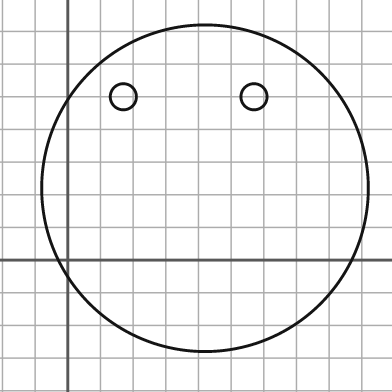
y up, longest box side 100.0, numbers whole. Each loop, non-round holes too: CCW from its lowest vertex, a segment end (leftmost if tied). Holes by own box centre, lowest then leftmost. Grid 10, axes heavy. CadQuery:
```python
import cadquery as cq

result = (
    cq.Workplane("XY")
    .moveTo(42.0, 22.0)
    .circle(50.0)
    .moveTo(17.0, 50.0)
    .circle(4.0)
    .moveTo(57.0, 50.0)
    .circle(4.0)
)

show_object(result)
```